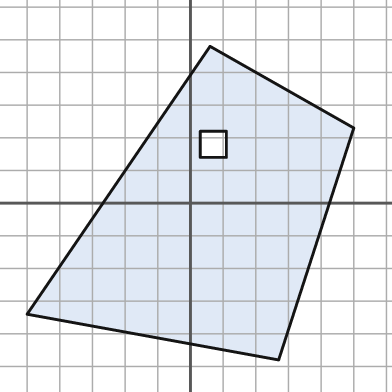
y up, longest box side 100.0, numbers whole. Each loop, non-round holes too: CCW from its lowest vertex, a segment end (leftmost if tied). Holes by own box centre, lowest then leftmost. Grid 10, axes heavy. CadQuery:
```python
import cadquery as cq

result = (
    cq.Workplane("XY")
    .moveTo(27.0, -48.0)
    .lineTo(50.0, 23.0)
    .lineTo(6.0, 48.0)
    .lineTo(-50.0, -34.0)
    .close()
    .moveTo(3.0, 14.0)
    .lineTo(11.0, 14.0)
    .lineTo(11.0, 22.0)
    .lineTo(3.0, 22.0)
    .close()
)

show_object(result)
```